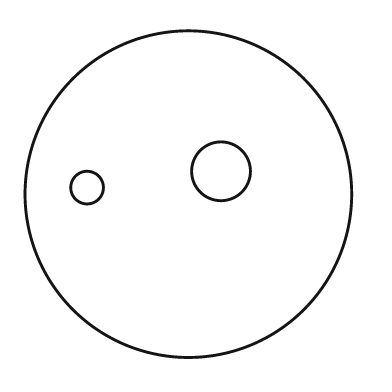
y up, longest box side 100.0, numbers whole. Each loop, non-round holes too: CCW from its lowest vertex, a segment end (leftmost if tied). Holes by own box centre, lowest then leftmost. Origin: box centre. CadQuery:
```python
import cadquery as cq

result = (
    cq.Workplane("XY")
    .moveTo(0.0, 0.0)
    .circle(50.0)
    .moveTo(-31.0, 2.0)
    .circle(5.0)
    .moveTo(10.0, 7.0)
    .circle(9.0)
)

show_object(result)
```